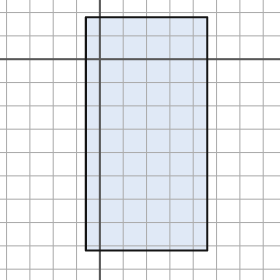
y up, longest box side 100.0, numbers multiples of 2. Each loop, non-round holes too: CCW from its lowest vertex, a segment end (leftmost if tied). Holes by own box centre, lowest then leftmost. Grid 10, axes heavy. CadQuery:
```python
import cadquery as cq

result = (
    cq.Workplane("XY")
    .moveTo(-6.0, -82.0)
    .lineTo(46.0, -82.0)
    .lineTo(46.0, 18.0)
    .lineTo(-6.0, 18.0)
    .close()
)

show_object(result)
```